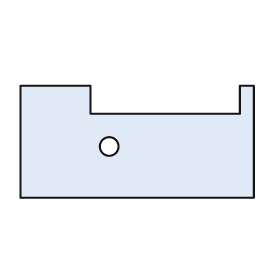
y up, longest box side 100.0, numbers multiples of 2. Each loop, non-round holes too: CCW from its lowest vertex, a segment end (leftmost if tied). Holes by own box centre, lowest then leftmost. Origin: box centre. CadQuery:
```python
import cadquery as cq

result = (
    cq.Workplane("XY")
    .moveTo(-50.0, -24.0)
    .lineTo(50.0, -24.0)
    .lineTo(50.0, 24.0)
    .lineTo(44.0, 24.0)
    .lineTo(44.0, 12.0)
    .lineTo(-20.0, 12.0)
    .lineTo(-20.0, 24.0)
    .lineTo(-50.0, 24.0)
    .close()
    .moveTo(-12.0, -2.0)
    .circle(4.0)
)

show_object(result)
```